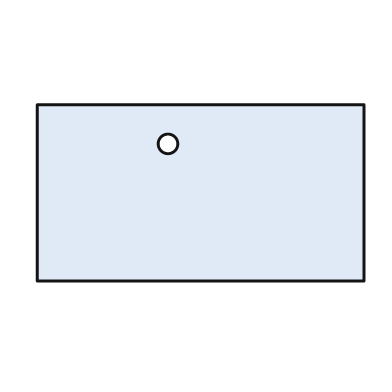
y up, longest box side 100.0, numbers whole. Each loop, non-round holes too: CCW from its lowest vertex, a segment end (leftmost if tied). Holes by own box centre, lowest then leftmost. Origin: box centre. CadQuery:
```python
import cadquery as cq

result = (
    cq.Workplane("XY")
    .moveTo(-50.0, -27.0)
    .lineTo(50.0, -27.0)
    .lineTo(50.0, 27.0)
    .lineTo(-50.0, 27.0)
    .close()
    .moveTo(-10.0, 15.0)
    .circle(3.0)
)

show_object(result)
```